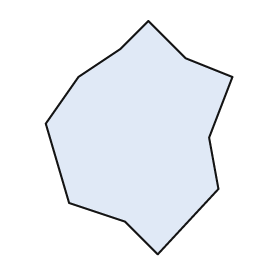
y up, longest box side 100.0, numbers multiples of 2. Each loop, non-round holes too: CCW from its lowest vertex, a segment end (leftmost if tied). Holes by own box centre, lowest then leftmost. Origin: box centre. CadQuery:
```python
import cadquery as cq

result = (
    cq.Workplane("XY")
    .moveTo(8.0, -50.0)
    .lineTo(34.0, -22.0)
    .lineTo(30.0, 0.0)
    .lineTo(40.0, 26.0)
    .lineTo(20.0, 34.0)
    .lineTo(4.0, 50.0)
    .lineTo(-8.0, 38.0)
    .lineTo(-26.0, 26.0)
    .lineTo(-40.0, 6.0)
    .lineTo(-30.0, -28.0)
    .lineTo(-6.0, -36.0)
    .close()
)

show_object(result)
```